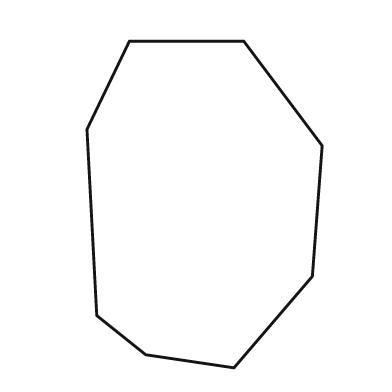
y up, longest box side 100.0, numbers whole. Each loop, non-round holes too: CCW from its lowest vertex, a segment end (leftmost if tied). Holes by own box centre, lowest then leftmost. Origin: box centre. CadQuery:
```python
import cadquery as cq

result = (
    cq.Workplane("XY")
    .moveTo(9.0, -50.0)
    .lineTo(33.0, -22.0)
    .lineTo(36.0, 18.0)
    .lineTo(12.0, 50.0)
    .lineTo(-23.0, 50.0)
    .lineTo(-36.0, 23.0)
    .lineTo(-33.0, -34.0)
    .lineTo(-18.0, -46.0)
    .close()
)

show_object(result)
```